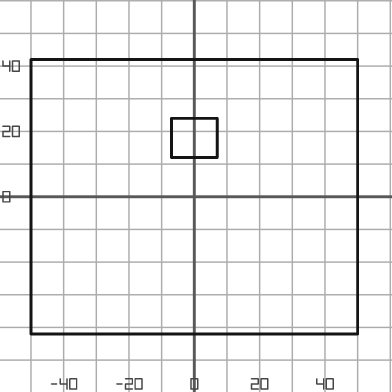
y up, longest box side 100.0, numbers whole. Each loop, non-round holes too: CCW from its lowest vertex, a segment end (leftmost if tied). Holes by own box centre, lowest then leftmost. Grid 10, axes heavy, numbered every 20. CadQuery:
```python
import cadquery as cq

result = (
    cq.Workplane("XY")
    .moveTo(-50.0, -42.0)
    .lineTo(50.0, -42.0)
    .lineTo(50.0, 42.0)
    .lineTo(-50.0, 42.0)
    .close()
    .moveTo(-7.0, 12.0)
    .lineTo(7.0, 12.0)
    .lineTo(7.0, 24.0)
    .lineTo(-7.0, 24.0)
    .close()
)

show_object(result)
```